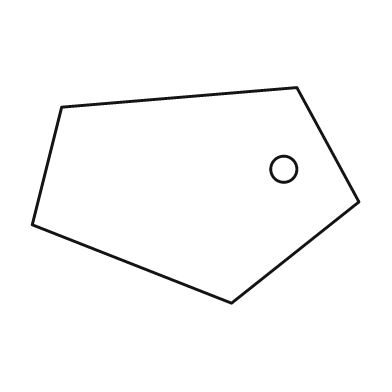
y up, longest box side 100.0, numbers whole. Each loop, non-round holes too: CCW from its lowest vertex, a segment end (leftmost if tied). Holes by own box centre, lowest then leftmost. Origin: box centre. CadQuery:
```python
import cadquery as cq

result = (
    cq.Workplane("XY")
    .moveTo(11.0, -33.0)
    .lineTo(50.0, -2.0)
    .lineTo(31.0, 33.0)
    .lineTo(-41.0, 27.0)
    .lineTo(-50.0, -9.0)
    .close()
    .moveTo(27.0, 8.0)
    .circle(4.0)
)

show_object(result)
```